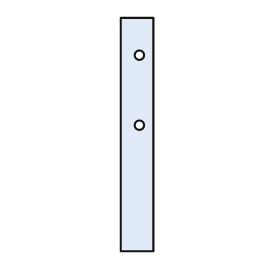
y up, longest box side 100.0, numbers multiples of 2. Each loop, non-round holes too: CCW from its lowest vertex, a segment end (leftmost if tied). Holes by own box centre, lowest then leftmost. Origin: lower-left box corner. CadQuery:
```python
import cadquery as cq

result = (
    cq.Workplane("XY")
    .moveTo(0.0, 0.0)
    .lineTo(14.0, 0.0)
    .lineTo(14.0, 100.0)
    .lineTo(0.0, 100.0)
    .close()
    .moveTo(8.0, 54.0)
    .circle(2.0)
    .moveTo(8.0, 84.0)
    .circle(2.0)
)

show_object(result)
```